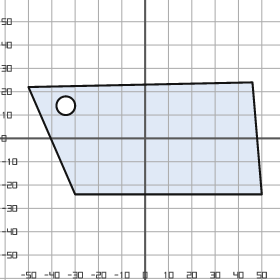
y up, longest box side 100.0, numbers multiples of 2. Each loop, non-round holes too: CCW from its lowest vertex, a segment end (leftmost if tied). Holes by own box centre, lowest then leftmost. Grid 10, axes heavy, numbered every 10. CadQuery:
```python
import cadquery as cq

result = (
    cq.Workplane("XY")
    .moveTo(-30.0, -24.0)
    .lineTo(50.0, -24.0)
    .lineTo(46.0, 24.0)
    .lineTo(-50.0, 22.0)
    .close()
    .moveTo(-34.0, 14.0)
    .circle(4.0)
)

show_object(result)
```